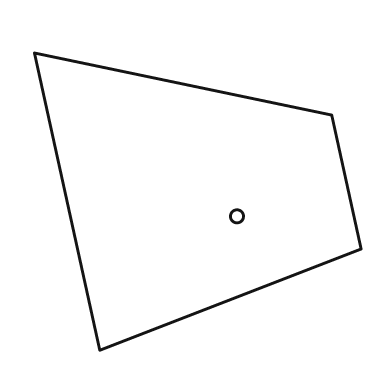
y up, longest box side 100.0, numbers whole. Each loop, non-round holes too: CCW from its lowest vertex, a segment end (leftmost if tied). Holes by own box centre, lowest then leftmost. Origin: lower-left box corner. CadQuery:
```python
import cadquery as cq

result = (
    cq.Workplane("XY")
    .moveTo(20.0, 0.0)
    .lineTo(100.0, 31.0)
    .lineTo(91.0, 72.0)
    .lineTo(0.0, 91.0)
    .close()
    .moveTo(62.0, 41.0)
    .circle(2.0)
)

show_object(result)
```